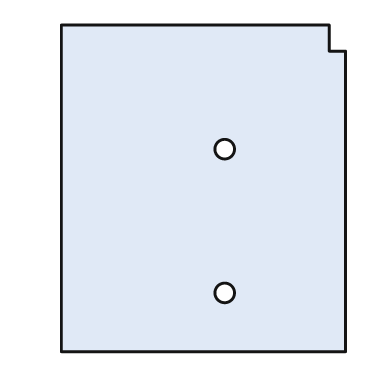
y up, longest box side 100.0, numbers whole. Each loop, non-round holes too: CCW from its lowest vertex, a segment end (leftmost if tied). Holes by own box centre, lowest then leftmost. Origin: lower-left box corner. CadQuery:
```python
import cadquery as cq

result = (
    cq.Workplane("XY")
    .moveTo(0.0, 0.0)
    .lineTo(87.0, 0.0)
    .lineTo(87.0, 92.0)
    .lineTo(82.0, 92.0)
    .lineTo(82.0, 100.0)
    .lineTo(0.0, 100.0)
    .close()
    .moveTo(50.0, 18.0)
    .circle(3.0)
    .moveTo(50.0, 62.0)
    .circle(3.0)
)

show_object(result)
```